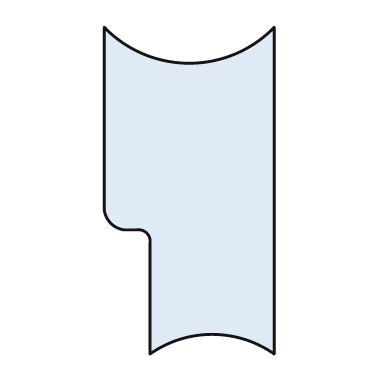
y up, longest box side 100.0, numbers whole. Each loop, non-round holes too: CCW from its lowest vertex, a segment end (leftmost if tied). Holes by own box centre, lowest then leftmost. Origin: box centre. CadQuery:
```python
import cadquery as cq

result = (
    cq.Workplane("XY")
    .moveTo(-12.0, -50.0)
    .threePointArc((7.0, -44.0), (26.0, -50.0))
    .lineTo(26.0, 50.0)
    .threePointArc((0.0, 39.0), (-26.0, 50.0))
    .lineTo(-26.0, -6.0)
    .threePointArc((-24.0, -10.0), (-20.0, -12.0))
    .lineTo(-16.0, -12.0)
    .threePointArc((-13.0, -13.0), (-12.0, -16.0))
    .close()
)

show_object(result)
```